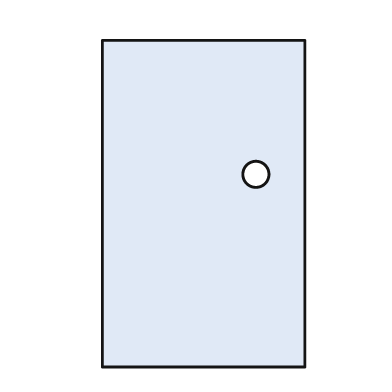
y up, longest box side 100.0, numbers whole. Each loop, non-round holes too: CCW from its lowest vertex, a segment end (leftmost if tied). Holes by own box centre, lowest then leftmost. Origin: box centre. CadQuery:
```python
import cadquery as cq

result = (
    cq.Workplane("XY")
    .moveTo(-31.0, -50.0)
    .lineTo(31.0, -50.0)
    .lineTo(31.0, 50.0)
    .lineTo(-31.0, 50.0)
    .close()
    .moveTo(16.0, 9.0)
    .circle(4.0)
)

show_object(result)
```